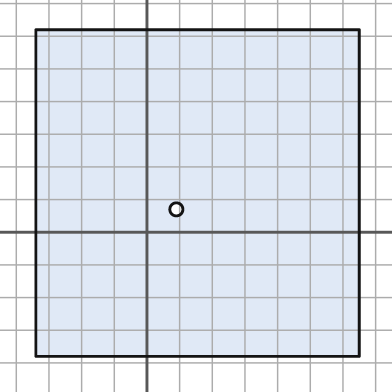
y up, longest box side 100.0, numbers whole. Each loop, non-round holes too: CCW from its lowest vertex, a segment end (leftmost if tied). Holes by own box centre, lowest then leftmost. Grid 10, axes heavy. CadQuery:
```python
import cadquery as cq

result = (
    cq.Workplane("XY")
    .moveTo(-34.0, -38.0)
    .lineTo(65.0, -38.0)
    .lineTo(65.0, 62.0)
    .lineTo(-34.0, 62.0)
    .close()
    .moveTo(9.0, 7.0)
    .circle(2.0)
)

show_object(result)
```